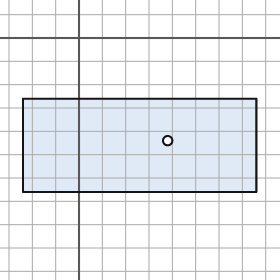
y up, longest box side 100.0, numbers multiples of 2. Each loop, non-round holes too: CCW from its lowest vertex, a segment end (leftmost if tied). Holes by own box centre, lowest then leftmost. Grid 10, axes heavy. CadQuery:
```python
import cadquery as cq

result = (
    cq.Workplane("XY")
    .moveTo(-24.0, -66.0)
    .lineTo(76.0, -66.0)
    .lineTo(76.0, -26.0)
    .lineTo(-24.0, -26.0)
    .close()
    .moveTo(38.0, -44.0)
    .circle(2.0)
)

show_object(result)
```